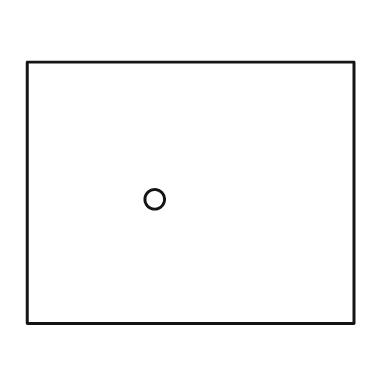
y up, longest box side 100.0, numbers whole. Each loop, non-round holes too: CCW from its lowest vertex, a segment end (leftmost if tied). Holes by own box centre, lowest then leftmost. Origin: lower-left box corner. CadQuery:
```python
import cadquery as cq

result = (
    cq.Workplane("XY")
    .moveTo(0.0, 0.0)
    .lineTo(100.0, 0.0)
    .lineTo(100.0, 80.0)
    .lineTo(0.0, 80.0)
    .close()
    .moveTo(39.0, 38.0)
    .circle(3.0)
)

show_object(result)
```